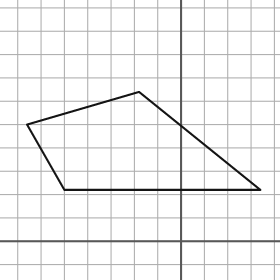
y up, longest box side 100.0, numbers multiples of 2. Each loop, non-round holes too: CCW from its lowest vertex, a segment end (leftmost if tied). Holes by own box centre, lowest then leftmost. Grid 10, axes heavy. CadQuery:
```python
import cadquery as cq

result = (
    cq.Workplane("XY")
    .moveTo(-50.0, 22.0)
    .lineTo(34.0, 22.0)
    .lineTo(-18.0, 64.0)
    .lineTo(-66.0, 50.0)
    .close()
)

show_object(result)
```